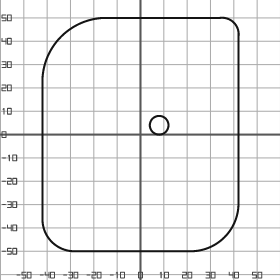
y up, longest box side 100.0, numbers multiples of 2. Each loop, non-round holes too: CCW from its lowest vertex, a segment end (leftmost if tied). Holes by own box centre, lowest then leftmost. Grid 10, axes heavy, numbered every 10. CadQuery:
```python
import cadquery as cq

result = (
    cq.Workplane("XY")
    .moveTo(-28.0, -50.0)
    .lineTo(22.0, -50.0)
    .threePointArc((36.0, -44.0), (42.0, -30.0))
    .lineTo(42.0, 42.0)
    .threePointArc((40.0, 48.0), (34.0, 50.0))
    .lineTo(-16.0, 50.0)
    .threePointArc((-34.0, 42.0), (-42.0, 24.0))
    .lineTo(-42.0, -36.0)
    .threePointArc((-38.0, -46.0), (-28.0, -50.0))
    .close()
    .moveTo(8.0, 4.0)
    .circle(4.0)
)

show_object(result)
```